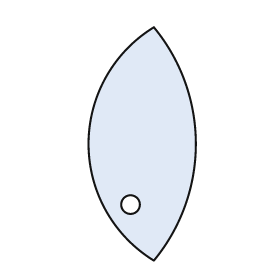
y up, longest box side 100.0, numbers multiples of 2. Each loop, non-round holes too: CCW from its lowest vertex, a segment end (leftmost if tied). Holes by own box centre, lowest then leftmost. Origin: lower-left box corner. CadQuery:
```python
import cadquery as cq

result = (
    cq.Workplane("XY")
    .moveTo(28.0, 0.0)
    .threePointArc((46.0, 50.0), (28.0, 100.0))
    .threePointArc((0.0, 50.0), (28.0, 0.0))
    .close()
    .moveTo(18.0, 24.0)
    .circle(4.0)
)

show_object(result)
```